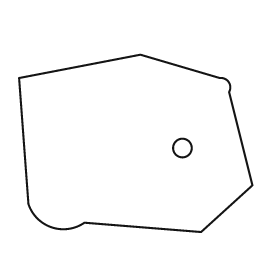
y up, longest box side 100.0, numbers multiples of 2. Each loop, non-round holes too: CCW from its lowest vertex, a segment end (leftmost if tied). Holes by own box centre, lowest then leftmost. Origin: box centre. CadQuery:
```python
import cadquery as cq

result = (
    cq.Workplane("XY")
    .moveTo(28.0, -38.0)
    .lineTo(50.0, -18.0)
    .lineTo(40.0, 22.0)
    .threePointArc((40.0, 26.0), (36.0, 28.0))
    .lineTo(2.0, 38.0)
    .lineTo(-50.0, 28.0)
    .lineTo(-46.0, -26.0)
    .threePointArc((-36.0, -36.0), (-22.0, -34.0))
    .close()
    .moveTo(20.0, -2.0)
    .circle(4.0)
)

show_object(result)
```